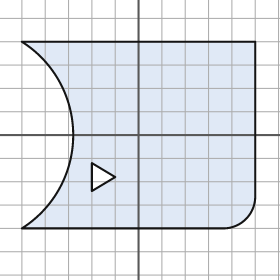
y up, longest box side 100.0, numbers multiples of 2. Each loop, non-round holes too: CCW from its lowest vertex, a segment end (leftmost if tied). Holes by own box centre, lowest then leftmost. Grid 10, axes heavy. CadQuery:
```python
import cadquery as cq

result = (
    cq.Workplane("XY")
    .moveTo(-50.0, -40.0)
    .lineTo(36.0, -40.0)
    .threePointArc((46.0, -36.0), (50.0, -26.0))
    .lineTo(50.0, 40.0)
    .lineTo(-50.0, 40.0)
    .threePointArc((-28.0, 0.0), (-50.0, -40.0))
    .close()
    .moveTo(-20.0, -24.0)
    .lineTo(-10.0, -18.0)
    .lineTo(-20.0, -12.0)
    .close()
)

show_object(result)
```